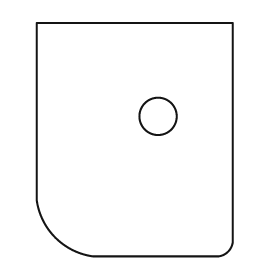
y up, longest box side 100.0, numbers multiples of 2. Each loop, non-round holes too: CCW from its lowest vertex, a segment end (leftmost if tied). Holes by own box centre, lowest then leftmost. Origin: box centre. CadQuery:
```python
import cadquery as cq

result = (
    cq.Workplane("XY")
    .moveTo(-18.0, -50.0)
    .lineTo(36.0, -50.0)
    .threePointArc((40.0, -48.0), (42.0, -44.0))
    .lineTo(42.0, 50.0)
    .lineTo(-42.0, 50.0)
    .lineTo(-42.0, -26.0)
    .threePointArc((-34.0, -42.0), (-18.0, -50.0))
    .close()
    .moveTo(10.0, 10.0)
    .circle(8.0)
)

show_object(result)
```